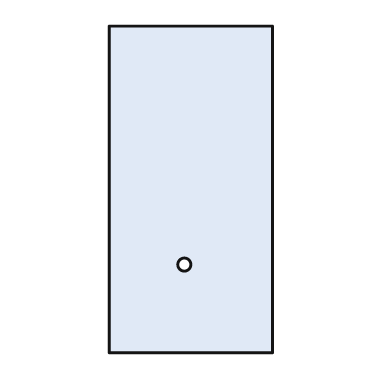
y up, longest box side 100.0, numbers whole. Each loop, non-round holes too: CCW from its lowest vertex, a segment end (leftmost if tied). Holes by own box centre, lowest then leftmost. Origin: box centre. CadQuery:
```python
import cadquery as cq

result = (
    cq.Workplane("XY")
    .moveTo(-25.0, -50.0)
    .lineTo(25.0, -50.0)
    .lineTo(25.0, 50.0)
    .lineTo(-25.0, 50.0)
    .close()
    .moveTo(-2.0, -23.0)
    .circle(2.0)
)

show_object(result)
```